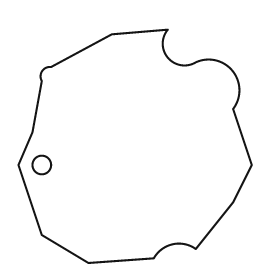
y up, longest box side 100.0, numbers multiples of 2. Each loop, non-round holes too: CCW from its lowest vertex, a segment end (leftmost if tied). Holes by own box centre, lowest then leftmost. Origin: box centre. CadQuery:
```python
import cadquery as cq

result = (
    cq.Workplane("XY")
    .moveTo(-20.0, -50.0)
    .lineTo(8.0, -48.0)
    .threePointArc((16.0, -42.0), (26.0, -44.0))
    .lineTo(42.0, -24.0)
    .lineTo(50.0, -8.0)
    .lineTo(42.0, 16.0)
    .threePointArc((42.0, 32.0), (26.0, 36.0))
    .threePointArc((14.0, 38.0), (14.0, 50.0))
    .lineTo(-10.0, 48.0)
    .lineTo(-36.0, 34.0)
    .threePointArc((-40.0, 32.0), (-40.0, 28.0))
    .lineTo(-44.0, 6.0)
    .lineTo(-50.0, -8.0)
    .lineTo(-40.0, -38.0)
    .close()
    .moveTo(-40.0, -8.0)
    .circle(4.0)
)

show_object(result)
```